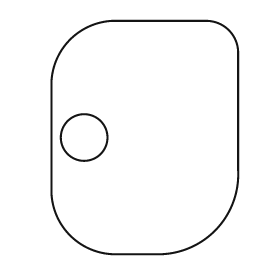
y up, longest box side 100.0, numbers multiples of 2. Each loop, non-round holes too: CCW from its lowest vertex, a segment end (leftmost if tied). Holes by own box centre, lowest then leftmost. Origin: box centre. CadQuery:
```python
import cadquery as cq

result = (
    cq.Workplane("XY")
    .moveTo(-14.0, -50.0)
    .lineTo(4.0, -50.0)
    .threePointArc((30.0, -40.0), (40.0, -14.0))
    .lineTo(40.0, 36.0)
    .threePointArc((36.0, 46.0), (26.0, 50.0))
    .lineTo(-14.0, 50.0)
    .threePointArc((-32.0, 42.0), (-40.0, 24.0))
    .lineTo(-40.0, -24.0)
    .threePointArc((-32.0, -42.0), (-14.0, -50.0))
    .close()
    .moveTo(-26.0, 0.0)
    .circle(10.0)
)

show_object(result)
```